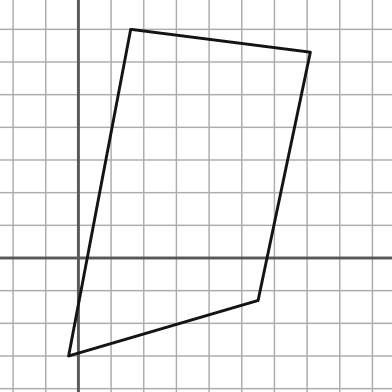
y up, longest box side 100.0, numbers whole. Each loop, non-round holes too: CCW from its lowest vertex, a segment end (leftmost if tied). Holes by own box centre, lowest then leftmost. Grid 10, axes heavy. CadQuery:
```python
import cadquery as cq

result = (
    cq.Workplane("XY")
    .moveTo(-3.0, -30.0)
    .lineTo(55.0, -13.0)
    .lineTo(71.0, 63.0)
    .lineTo(16.0, 70.0)
    .close()
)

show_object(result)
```